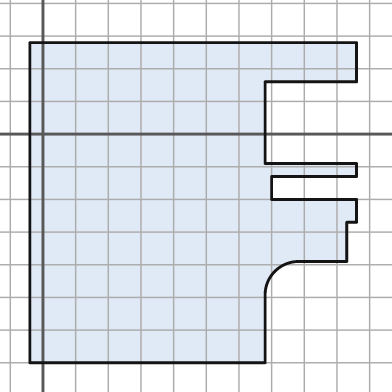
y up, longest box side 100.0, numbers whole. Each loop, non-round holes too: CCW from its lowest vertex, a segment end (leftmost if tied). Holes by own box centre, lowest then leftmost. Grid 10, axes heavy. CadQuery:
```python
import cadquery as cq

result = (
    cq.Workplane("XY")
    .moveTo(-4.0, -70.0)
    .lineTo(68.0, -70.0)
    .lineTo(68.0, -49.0)
    .threePointArc((71.0, -42.0), (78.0, -39.0))
    .lineTo(93.0, -39.0)
    .lineTo(93.0, -27.0)
    .lineTo(96.0, -27.0)
    .lineTo(96.0, -20.0)
    .lineTo(70.0, -20.0)
    .lineTo(70.0, -13.0)
    .lineTo(96.0, -13.0)
    .lineTo(96.0, -9.0)
    .lineTo(68.0, -9.0)
    .lineTo(68.0, 16.0)
    .lineTo(96.0, 16.0)
    .lineTo(96.0, 28.0)
    .lineTo(-4.0, 28.0)
    .close()
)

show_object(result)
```